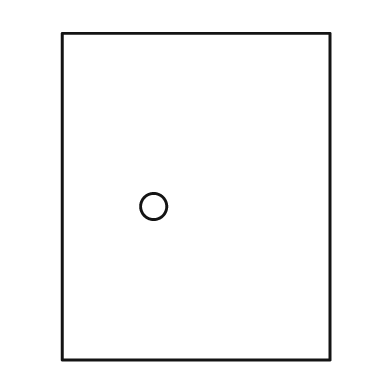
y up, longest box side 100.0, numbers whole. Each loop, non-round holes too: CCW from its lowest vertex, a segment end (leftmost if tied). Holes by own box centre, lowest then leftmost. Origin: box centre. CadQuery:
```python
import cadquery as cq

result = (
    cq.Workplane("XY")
    .moveTo(-41.0, -50.0)
    .lineTo(41.0, -50.0)
    .lineTo(41.0, 50.0)
    .lineTo(-41.0, 50.0)
    .close()
    .moveTo(-13.0, -3.0)
    .circle(4.0)
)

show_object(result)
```